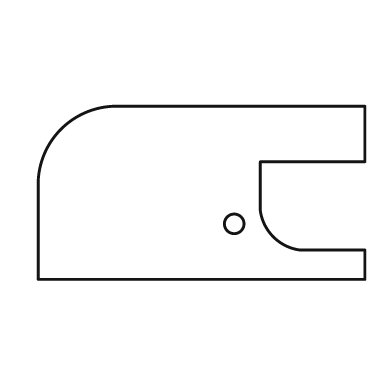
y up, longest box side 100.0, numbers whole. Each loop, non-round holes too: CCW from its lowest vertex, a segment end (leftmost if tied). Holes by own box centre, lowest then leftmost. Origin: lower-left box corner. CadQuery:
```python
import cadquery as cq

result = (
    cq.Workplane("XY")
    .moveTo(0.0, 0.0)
    .lineTo(100.0, 0.0)
    .lineTo(100.0, 9.0)
    .lineTo(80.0, 9.0)
    .threePointArc((72.0, 13.0), (68.0, 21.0))
    .lineTo(68.0, 36.0)
    .lineTo(100.0, 36.0)
    .lineTo(100.0, 53.0)
    .lineTo(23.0, 53.0)
    .threePointArc((7.0, 46.0), (0.0, 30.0))
    .close()
    .moveTo(60.0, 17.0)
    .circle(3.0)
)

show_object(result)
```